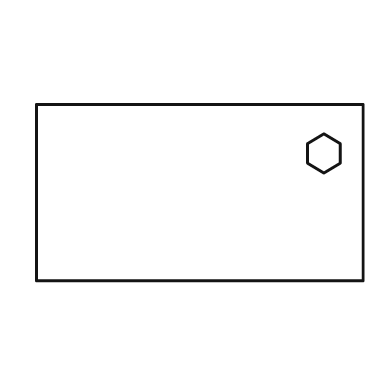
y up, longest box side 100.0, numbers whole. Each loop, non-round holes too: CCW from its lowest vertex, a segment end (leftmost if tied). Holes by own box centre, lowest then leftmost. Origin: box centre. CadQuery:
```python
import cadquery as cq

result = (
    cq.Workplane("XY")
    .moveTo(-50.0, -27.0)
    .lineTo(50.0, -27.0)
    .lineTo(50.0, 27.0)
    .lineTo(-50.0, 27.0)
    .close()
    .moveTo(38.0, 6.0)
    .lineTo(43.0, 9.0)
    .lineTo(43.0, 15.0)
    .lineTo(38.0, 18.0)
    .lineTo(33.0, 15.0)
    .lineTo(33.0, 9.0)
    .close()
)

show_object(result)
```